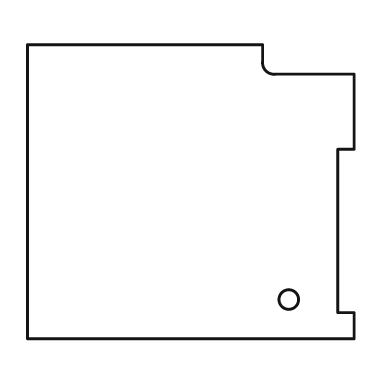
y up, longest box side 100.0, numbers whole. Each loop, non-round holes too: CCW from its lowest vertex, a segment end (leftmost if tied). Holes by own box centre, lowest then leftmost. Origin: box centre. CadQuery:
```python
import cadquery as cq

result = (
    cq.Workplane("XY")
    .moveTo(-50.0, -45.0)
    .lineTo(50.0, -45.0)
    .lineTo(50.0, -37.0)
    .lineTo(45.0, -37.0)
    .lineTo(45.0, 13.0)
    .lineTo(50.0, 13.0)
    .lineTo(50.0, 36.0)
    .lineTo(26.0, 36.0)
    .threePointArc((23.0, 37.0), (22.0, 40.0))
    .lineTo(22.0, 45.0)
    .lineTo(-50.0, 45.0)
    .close()
    .moveTo(30.0, -33.0)
    .circle(3.0)
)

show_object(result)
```